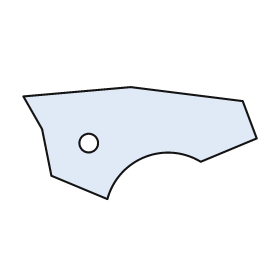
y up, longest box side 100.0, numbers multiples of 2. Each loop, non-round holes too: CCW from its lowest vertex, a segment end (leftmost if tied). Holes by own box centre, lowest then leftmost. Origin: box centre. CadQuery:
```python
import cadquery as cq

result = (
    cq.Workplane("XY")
    .moveTo(-14.0, -24.0)
    .threePointArc((2.0, -6.0), (26.0, -8.0))
    .lineTo(50.0, 2.0)
    .lineTo(44.0, 18.0)
    .lineTo(-4.0, 24.0)
    .lineTo(-50.0, 20.0)
    .lineTo(-42.0, 6.0)
    .lineTo(-38.0, -14.0)
    .close()
    .moveTo(-22.0, 0.0)
    .circle(4.0)
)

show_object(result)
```